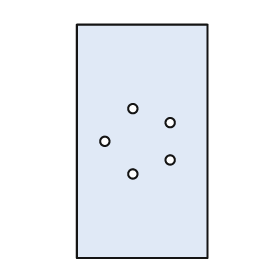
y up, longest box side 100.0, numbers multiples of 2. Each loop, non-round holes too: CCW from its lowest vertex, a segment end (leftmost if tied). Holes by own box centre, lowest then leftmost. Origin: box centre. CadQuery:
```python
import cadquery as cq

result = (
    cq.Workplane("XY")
    .moveTo(-28.0, -50.0)
    .lineTo(28.0, -50.0)
    .lineTo(28.0, 50.0)
    .lineTo(-28.0, 50.0)
    .close()
    .moveTo(-4.0, -14.0)
    .circle(2.0)
    .moveTo(12.0, -8.0)
    .circle(2.0)
    .moveTo(-16.0, 0.0)
    .circle(2.0)
    .moveTo(12.0, 8.0)
    .circle(2.0)
    .moveTo(-4.0, 14.0)
    .circle(2.0)
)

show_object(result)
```